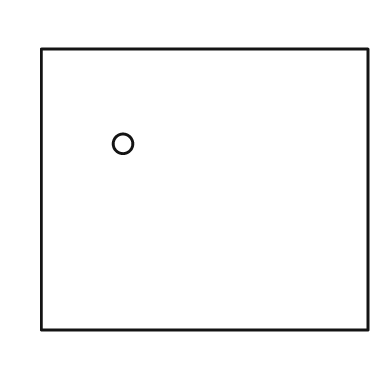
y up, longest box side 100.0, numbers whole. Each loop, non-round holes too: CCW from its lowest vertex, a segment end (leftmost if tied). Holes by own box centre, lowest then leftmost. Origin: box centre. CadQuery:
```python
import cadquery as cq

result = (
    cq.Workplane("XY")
    .moveTo(-50.0, -43.0)
    .lineTo(50.0, -43.0)
    .lineTo(50.0, 43.0)
    .lineTo(-50.0, 43.0)
    .close()
    .moveTo(-25.0, 14.0)
    .circle(3.0)
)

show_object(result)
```